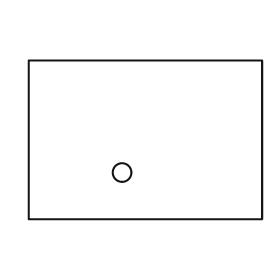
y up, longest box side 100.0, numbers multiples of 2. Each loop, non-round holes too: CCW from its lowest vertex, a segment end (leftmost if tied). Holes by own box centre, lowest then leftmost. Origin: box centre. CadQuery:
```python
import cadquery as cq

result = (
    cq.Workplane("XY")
    .moveTo(-50.0, -34.0)
    .lineTo(50.0, -34.0)
    .lineTo(50.0, 34.0)
    .lineTo(-50.0, 34.0)
    .close()
    .moveTo(-10.0, -14.0)
    .circle(4.0)
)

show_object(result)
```